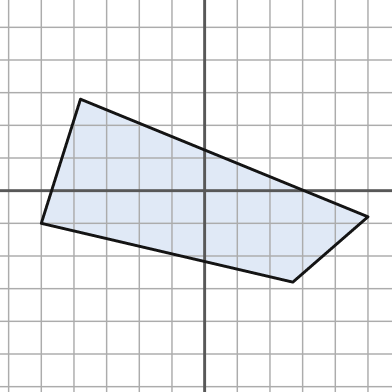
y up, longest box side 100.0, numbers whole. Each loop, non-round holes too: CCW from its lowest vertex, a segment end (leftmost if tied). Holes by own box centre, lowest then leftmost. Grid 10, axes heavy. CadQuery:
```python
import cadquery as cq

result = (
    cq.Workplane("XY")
    .moveTo(27.0, -28.0)
    .lineTo(50.0, -8.0)
    .lineTo(-38.0, 28.0)
    .lineTo(-50.0, -10.0)
    .close()
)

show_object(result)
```